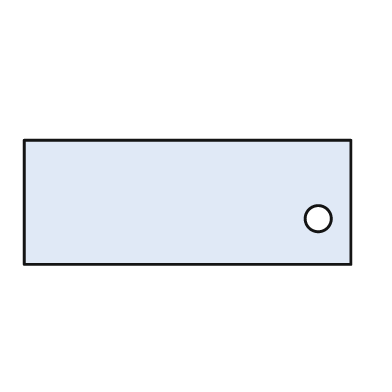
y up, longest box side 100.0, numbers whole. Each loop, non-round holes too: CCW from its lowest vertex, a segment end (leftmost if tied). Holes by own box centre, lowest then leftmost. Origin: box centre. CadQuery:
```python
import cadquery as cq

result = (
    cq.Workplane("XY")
    .moveTo(-50.0, -19.0)
    .lineTo(50.0, -19.0)
    .lineTo(50.0, 19.0)
    .lineTo(-50.0, 19.0)
    .close()
    .moveTo(40.0, -5.0)
    .circle(4.0)
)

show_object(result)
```